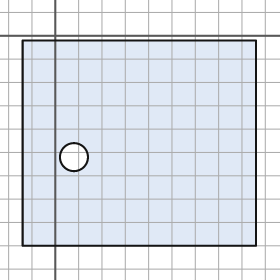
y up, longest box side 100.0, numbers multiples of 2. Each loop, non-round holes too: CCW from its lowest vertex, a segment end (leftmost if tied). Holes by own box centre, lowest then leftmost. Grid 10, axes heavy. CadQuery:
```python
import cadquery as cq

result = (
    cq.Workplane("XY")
    .moveTo(-14.0, -90.0)
    .lineTo(86.0, -90.0)
    .lineTo(86.0, -2.0)
    .lineTo(-14.0, -2.0)
    .close()
    .moveTo(8.0, -52.0)
    .circle(6.0)
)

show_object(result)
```